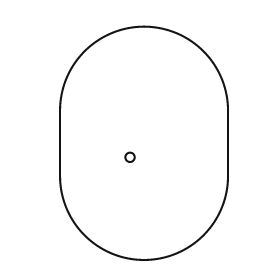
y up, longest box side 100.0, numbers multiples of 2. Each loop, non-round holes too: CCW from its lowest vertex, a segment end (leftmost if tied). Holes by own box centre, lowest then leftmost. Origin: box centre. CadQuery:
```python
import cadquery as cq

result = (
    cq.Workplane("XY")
    .moveTo(-36.0, -14.0)
    .threePointArc((0.0, -50.0), (36.0, -14.0))
    .lineTo(36.0, 14.0)
    .threePointArc((0.0, 50.0), (-36.0, 14.0))
    .close()
    .moveTo(-6.0, -6.0)
    .circle(2.0)
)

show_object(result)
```